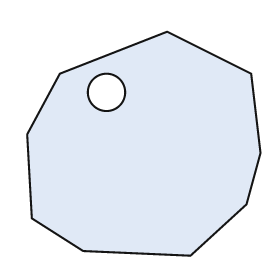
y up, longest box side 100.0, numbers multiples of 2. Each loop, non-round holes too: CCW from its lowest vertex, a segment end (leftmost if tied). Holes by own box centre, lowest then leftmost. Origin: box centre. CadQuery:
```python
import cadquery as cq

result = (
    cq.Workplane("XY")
    .moveTo(20.0, -48.0)
    .lineTo(44.0, -26.0)
    .lineTo(50.0, -4.0)
    .lineTo(46.0, 30.0)
    .lineTo(10.0, 48.0)
    .lineTo(-36.0, 30.0)
    .lineTo(-50.0, 4.0)
    .lineTo(-48.0, -32.0)
    .lineTo(-26.0, -46.0)
    .close()
    .moveTo(-16.0, 22.0)
    .circle(8.0)
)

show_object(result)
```